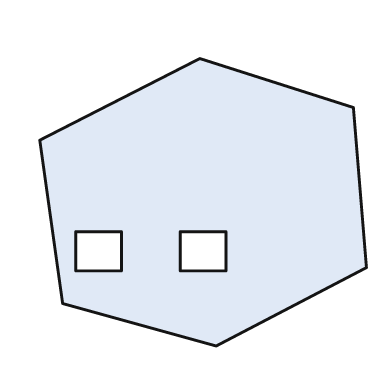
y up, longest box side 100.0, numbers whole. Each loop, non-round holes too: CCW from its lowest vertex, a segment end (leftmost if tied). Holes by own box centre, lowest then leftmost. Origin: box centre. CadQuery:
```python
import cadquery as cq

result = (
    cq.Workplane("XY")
    .moveTo(4.0, -44.0)
    .lineTo(50.0, -20.0)
    .lineTo(46.0, 29.0)
    .lineTo(-1.0, 44.0)
    .lineTo(-50.0, 19.0)
    .lineTo(-43.0, -31.0)
    .close()
    .moveTo(-39.0, -21.0)
    .lineTo(-25.0, -21.0)
    .lineTo(-25.0, -9.0)
    .lineTo(-39.0, -9.0)
    .close()
    .moveTo(-7.0, -21.0)
    .lineTo(7.0, -21.0)
    .lineTo(7.0, -9.0)
    .lineTo(-7.0, -9.0)
    .close()
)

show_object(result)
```